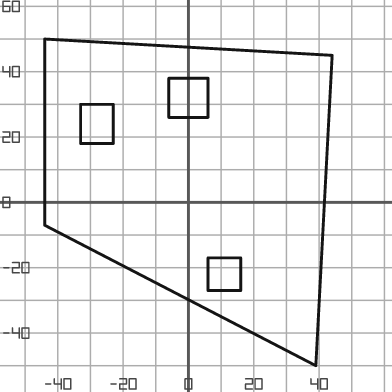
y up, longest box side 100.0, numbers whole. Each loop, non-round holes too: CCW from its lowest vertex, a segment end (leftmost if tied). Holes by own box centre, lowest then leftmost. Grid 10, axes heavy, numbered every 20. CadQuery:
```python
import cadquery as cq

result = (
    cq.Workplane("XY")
    .moveTo(39.0, -50.0)
    .lineTo(44.0, 45.0)
    .lineTo(-44.0, 50.0)
    .lineTo(-44.0, -7.0)
    .close()
    .moveTo(6.0, -27.0)
    .lineTo(16.0, -27.0)
    .lineTo(16.0, -17.0)
    .lineTo(6.0, -17.0)
    .close()
    .moveTo(-33.0, 18.0)
    .lineTo(-23.0, 18.0)
    .lineTo(-23.0, 30.0)
    .lineTo(-33.0, 30.0)
    .close()
    .moveTo(-6.0, 26.0)
    .lineTo(6.0, 26.0)
    .lineTo(6.0, 38.0)
    .lineTo(-6.0, 38.0)
    .close()
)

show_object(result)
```